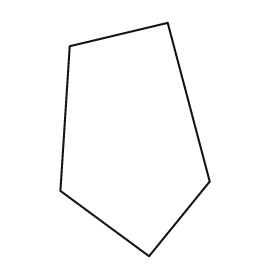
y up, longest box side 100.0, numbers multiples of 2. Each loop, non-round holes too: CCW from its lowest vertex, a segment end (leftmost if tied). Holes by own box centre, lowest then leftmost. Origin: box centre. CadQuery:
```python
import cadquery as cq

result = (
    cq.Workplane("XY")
    .moveTo(6.0, -50.0)
    .lineTo(32.0, -18.0)
    .lineTo(14.0, 50.0)
    .lineTo(-28.0, 40.0)
    .lineTo(-32.0, -22.0)
    .close()
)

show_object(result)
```